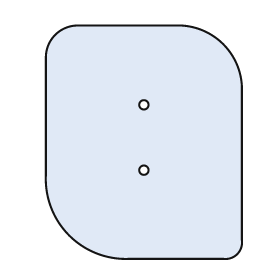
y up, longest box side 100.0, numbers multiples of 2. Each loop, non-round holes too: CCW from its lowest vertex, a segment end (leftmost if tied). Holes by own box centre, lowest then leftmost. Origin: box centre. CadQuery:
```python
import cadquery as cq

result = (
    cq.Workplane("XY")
    .moveTo(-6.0, -50.0)
    .lineTo(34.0, -50.0)
    .threePointArc((40.0, -48.0), (42.0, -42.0))
    .lineTo(42.0, 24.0)
    .threePointArc((34.0, 42.0), (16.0, 50.0))
    .lineTo(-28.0, 50.0)
    .threePointArc((-38.0, 46.0), (-42.0, 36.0))
    .lineTo(-42.0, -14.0)
    .threePointArc((-32.0, -40.0), (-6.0, -50.0))
    .close()
    .moveTo(0.0, -12.0)
    .circle(2.0)
    .moveTo(0.0, 16.0)
    .circle(2.0)
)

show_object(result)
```